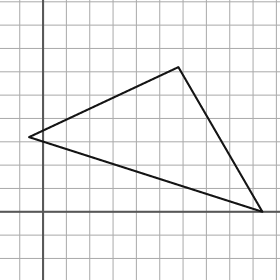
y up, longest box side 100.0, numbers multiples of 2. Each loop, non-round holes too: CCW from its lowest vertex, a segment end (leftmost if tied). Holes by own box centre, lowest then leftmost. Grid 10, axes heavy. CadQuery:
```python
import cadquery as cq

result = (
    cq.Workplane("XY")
    .moveTo(94.0, 0.0)
    .lineTo(58.0, 62.0)
    .lineTo(-6.0, 32.0)
    .close()
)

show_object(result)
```